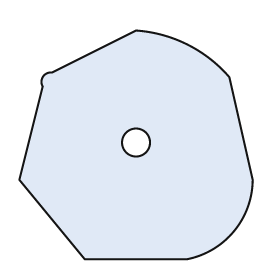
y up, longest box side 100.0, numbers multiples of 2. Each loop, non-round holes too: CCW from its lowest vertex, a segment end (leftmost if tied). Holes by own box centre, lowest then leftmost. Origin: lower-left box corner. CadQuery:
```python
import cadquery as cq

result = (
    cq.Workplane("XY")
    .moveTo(28.0, 0.0)
    .lineTo(72.0, 0.0)
    .threePointArc((92.0, 12.0), (100.0, 34.0))
    .lineTo(90.0, 78.0)
    .threePointArc((72.0, 92.0), (50.0, 98.0))
    .lineTo(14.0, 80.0)
    .threePointArc((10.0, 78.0), (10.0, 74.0))
    .lineTo(0.0, 34.0)
    .close()
    .moveTo(50.0, 50.0)
    .circle(6.0)
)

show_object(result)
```